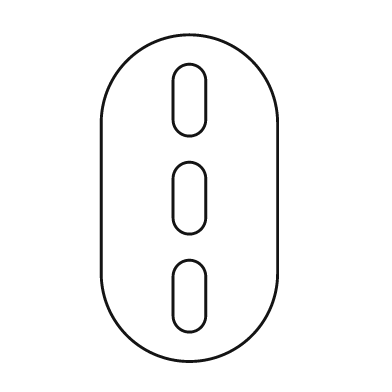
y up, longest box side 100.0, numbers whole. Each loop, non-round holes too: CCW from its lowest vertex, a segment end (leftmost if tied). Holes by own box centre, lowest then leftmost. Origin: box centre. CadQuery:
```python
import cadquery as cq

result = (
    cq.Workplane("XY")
    .moveTo(-27.0, -23.0)
    .threePointArc((0.0, -50.0), (27.0, -23.0))
    .lineTo(27.0, 23.0)
    .threePointArc((0.0, 50.0), (-27.0, 23.0))
    .close()
    .moveTo(-5.0, -36.0)
    .threePointArc((0.0, -41.0), (5.0, -36.0))
    .lineTo(5.0, -24.0)
    .threePointArc((0.0, -19.0), (-5.0, -24.0))
    .close()
    .moveTo(-5.0, -6.0)
    .threePointArc((0.0, -11.0), (5.0, -6.0))
    .lineTo(5.0, 6.0)
    .threePointArc((0.0, 11.0), (-5.0, 6.0))
    .close()
    .moveTo(-5.0, 24.0)
    .threePointArc((0.0, 19.0), (5.0, 24.0))
    .lineTo(5.0, 36.0)
    .threePointArc((0.0, 41.0), (-5.0, 36.0))
    .close()
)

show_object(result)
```